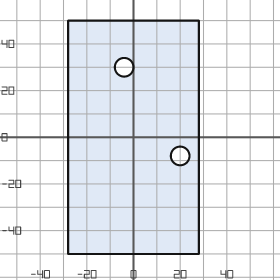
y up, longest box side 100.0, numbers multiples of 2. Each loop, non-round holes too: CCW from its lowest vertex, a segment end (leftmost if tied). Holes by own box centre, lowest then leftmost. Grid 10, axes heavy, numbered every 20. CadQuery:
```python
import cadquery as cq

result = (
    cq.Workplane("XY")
    .moveTo(-28.0, -50.0)
    .lineTo(28.0, -50.0)
    .lineTo(28.0, 50.0)
    .lineTo(-28.0, 50.0)
    .close()
    .moveTo(20.0, -8.0)
    .circle(4.0)
    .moveTo(-4.0, 30.0)
    .circle(4.0)
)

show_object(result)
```